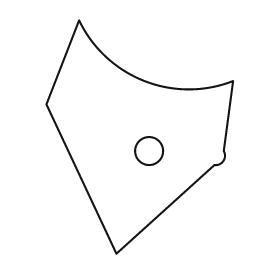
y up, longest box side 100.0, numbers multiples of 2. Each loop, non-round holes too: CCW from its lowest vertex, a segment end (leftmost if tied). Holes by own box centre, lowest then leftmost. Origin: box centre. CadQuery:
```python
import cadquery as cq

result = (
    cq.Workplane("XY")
    .moveTo(-10.0, -50.0)
    .lineTo(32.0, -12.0)
    .threePointArc((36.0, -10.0), (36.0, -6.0))
    .lineTo(40.0, 24.0)
    .threePointArc((2.0, 24.0), (-26.0, 50.0))
    .lineTo(-40.0, 14.0)
    .close()
    .moveTo(4.0, -6.0)
    .circle(6.0)
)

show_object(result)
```